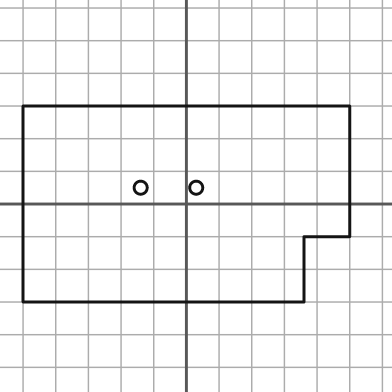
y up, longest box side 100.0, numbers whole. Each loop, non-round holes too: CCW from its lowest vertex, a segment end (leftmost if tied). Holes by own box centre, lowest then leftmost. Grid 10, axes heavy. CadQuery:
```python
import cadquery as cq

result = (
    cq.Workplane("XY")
    .moveTo(-50.0, -30.0)
    .lineTo(36.0, -30.0)
    .lineTo(36.0, -10.0)
    .lineTo(50.0, -10.0)
    .lineTo(50.0, 30.0)
    .lineTo(-50.0, 30.0)
    .close()
    .moveTo(-14.0, 5.0)
    .circle(2.0)
    .moveTo(3.0, 5.0)
    .circle(2.0)
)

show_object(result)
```